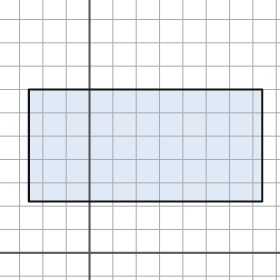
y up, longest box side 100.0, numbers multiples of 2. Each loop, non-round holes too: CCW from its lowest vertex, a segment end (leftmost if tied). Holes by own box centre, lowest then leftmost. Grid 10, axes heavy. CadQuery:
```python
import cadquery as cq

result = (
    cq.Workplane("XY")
    .moveTo(-26.0, 22.0)
    .lineTo(74.0, 22.0)
    .lineTo(74.0, 70.0)
    .lineTo(-26.0, 70.0)
    .close()
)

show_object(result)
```